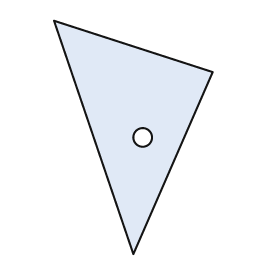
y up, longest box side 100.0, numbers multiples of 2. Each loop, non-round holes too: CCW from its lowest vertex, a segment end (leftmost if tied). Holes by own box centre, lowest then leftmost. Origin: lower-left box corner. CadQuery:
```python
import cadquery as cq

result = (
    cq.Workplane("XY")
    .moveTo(34.0, 0.0)
    .lineTo(68.0, 78.0)
    .lineTo(0.0, 100.0)
    .close()
    .moveTo(38.0, 50.0)
    .circle(4.0)
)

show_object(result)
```